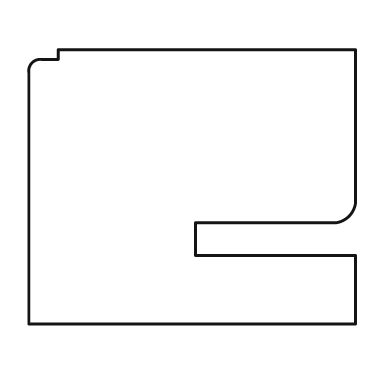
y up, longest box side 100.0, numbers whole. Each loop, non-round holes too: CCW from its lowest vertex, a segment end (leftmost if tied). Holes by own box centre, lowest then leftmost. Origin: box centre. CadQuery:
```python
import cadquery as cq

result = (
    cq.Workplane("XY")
    .moveTo(-50.0, -42.0)
    .lineTo(50.0, -42.0)
    .lineTo(50.0, -21.0)
    .lineTo(1.0, -21.0)
    .lineTo(1.0, -11.0)
    .lineTo(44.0, -11.0)
    .threePointArc((48.0, -9.0), (50.0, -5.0))
    .lineTo(50.0, 42.0)
    .lineTo(-41.0, 42.0)
    .lineTo(-41.0, 39.0)
    .lineTo(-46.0, 39.0)
    .threePointArc((-49.0, 38.0), (-50.0, 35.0))
    .close()
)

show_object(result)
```